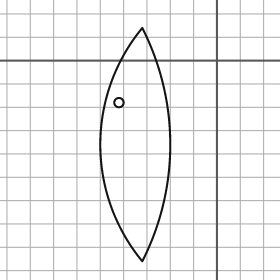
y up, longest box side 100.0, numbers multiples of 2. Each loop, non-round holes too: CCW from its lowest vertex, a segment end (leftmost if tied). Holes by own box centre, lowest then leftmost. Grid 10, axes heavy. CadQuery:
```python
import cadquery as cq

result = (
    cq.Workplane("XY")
    .moveTo(-32.0, -86.0)
    .threePointArc((-20.0, -36.0), (-32.0, 14.0))
    .threePointArc((-50.0, -36.0), (-32.0, -86.0))
    .close()
    .moveTo(-42.0, -18.0)
    .circle(2.0)
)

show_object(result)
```